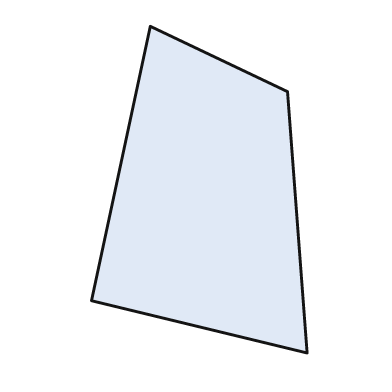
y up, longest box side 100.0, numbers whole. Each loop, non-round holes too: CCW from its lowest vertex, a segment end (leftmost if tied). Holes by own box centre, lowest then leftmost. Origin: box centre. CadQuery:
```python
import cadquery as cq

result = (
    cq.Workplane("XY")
    .moveTo(33.0, -50.0)
    .lineTo(27.0, 30.0)
    .lineTo(-15.0, 50.0)
    .lineTo(-33.0, -34.0)
    .close()
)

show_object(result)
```